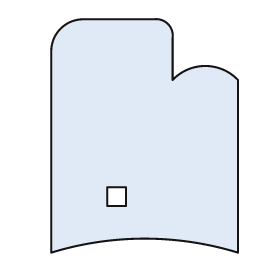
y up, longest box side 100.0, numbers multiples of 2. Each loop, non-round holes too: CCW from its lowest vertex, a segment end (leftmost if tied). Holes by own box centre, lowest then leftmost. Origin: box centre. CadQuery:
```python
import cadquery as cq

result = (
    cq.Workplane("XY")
    .moveTo(-40.0, -50.0)
    .threePointArc((0.0, -44.0), (40.0, -50.0))
    .lineTo(40.0, 24.0)
    .threePointArc((26.0, 30.0), (12.0, 24.0))
    .lineTo(12.0, 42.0)
    .threePointArc((10.0, 48.0), (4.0, 50.0))
    .lineTo(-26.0, 50.0)
    .threePointArc((-36.0, 46.0), (-40.0, 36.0))
    .close()
    .moveTo(-16.0, -30.0)
    .lineTo(-8.0, -30.0)
    .lineTo(-8.0, -22.0)
    .lineTo(-16.0, -22.0)
    .close()
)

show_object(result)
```